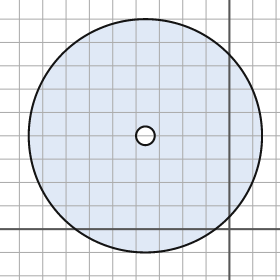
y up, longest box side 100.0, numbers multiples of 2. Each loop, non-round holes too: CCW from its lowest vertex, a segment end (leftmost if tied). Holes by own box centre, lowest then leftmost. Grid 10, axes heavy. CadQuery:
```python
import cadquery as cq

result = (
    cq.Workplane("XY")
    .moveTo(-36.0, 40.0)
    .circle(50.0)
    .moveTo(-36.0, 40.0)
    .circle(4.0)
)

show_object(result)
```